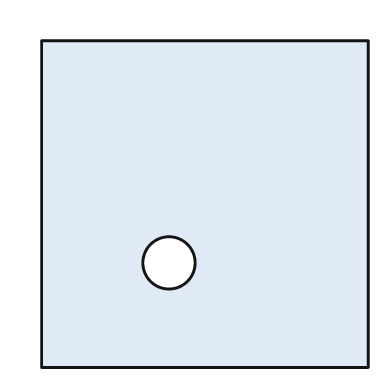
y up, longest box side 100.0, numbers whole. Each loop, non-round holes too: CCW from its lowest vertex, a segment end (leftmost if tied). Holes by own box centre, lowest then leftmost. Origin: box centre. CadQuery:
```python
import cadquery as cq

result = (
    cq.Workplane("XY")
    .moveTo(-50.0, -50.0)
    .lineTo(50.0, -50.0)
    .lineTo(50.0, 50.0)
    .lineTo(-50.0, 50.0)
    .close()
    .moveTo(-11.0, -18.0)
    .circle(8.0)
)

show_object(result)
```